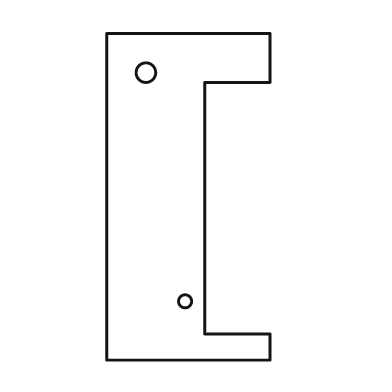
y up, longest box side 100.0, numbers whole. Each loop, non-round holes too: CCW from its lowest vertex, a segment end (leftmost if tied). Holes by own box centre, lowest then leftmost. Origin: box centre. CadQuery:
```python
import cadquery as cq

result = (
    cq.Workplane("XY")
    .moveTo(-25.0, -50.0)
    .lineTo(25.0, -50.0)
    .lineTo(25.0, -42.0)
    .lineTo(5.0, -42.0)
    .lineTo(5.0, 35.0)
    .lineTo(25.0, 35.0)
    .lineTo(25.0, 50.0)
    .lineTo(-25.0, 50.0)
    .close()
    .moveTo(-1.0, -32.0)
    .circle(2.0)
    .moveTo(-13.0, 38.0)
    .circle(3.0)
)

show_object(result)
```